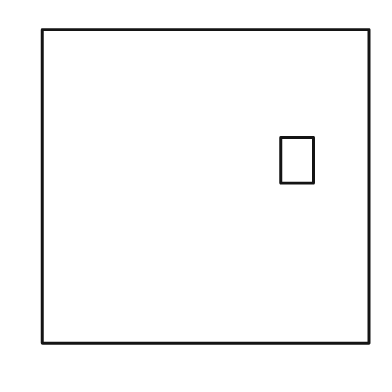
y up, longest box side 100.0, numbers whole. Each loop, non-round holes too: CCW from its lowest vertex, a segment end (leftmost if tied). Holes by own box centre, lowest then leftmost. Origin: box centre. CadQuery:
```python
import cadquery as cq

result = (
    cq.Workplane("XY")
    .moveTo(-50.0, -48.0)
    .lineTo(50.0, -48.0)
    .lineTo(50.0, 48.0)
    .lineTo(-50.0, 48.0)
    .close()
    .moveTo(23.0, 1.0)
    .lineTo(33.0, 1.0)
    .lineTo(33.0, 15.0)
    .lineTo(23.0, 15.0)
    .close()
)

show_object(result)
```